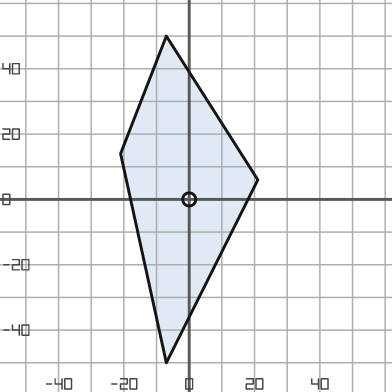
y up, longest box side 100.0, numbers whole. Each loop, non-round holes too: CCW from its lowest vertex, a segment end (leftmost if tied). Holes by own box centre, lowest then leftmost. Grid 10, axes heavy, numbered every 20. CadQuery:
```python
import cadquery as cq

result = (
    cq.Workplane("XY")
    .moveTo(-7.0, -50.0)
    .lineTo(21.0, 6.0)
    .lineTo(-7.0, 50.0)
    .lineTo(-21.0, 14.0)
    .close()
    .moveTo(0.0, 0.0)
    .circle(2.0)
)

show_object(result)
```